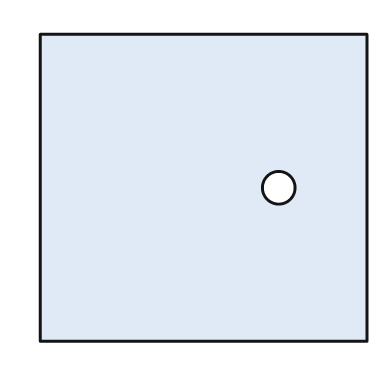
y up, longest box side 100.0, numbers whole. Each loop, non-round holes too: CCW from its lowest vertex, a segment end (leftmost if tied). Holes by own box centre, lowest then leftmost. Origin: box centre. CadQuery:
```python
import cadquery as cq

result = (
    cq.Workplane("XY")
    .moveTo(-50.0, -47.0)
    .lineTo(50.0, -47.0)
    .lineTo(50.0, 47.0)
    .lineTo(-50.0, 47.0)
    .close()
    .moveTo(23.0, 0.0)
    .circle(5.0)
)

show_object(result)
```